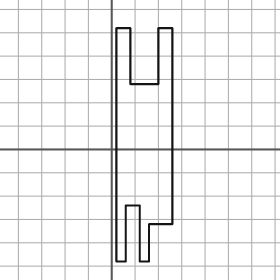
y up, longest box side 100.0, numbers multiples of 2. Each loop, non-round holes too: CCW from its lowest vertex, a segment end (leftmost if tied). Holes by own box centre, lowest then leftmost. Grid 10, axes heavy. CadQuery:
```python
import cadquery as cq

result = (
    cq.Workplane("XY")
    .moveTo(2.0, -48.0)
    .lineTo(6.0, -48.0)
    .lineTo(6.0, -24.0)
    .lineTo(12.0, -24.0)
    .lineTo(12.0, -48.0)
    .lineTo(16.0, -48.0)
    .lineTo(16.0, -32.0)
    .lineTo(26.0, -32.0)
    .lineTo(26.0, 52.0)
    .lineTo(20.0, 52.0)
    .lineTo(20.0, 28.0)
    .lineTo(8.0, 28.0)
    .lineTo(8.0, 52.0)
    .lineTo(2.0, 52.0)
    .close()
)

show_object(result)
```